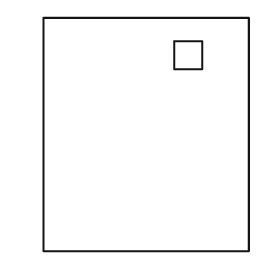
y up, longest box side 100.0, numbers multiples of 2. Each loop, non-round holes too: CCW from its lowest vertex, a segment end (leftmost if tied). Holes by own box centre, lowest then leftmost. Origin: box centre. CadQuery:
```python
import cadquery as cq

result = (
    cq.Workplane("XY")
    .moveTo(-44.0, -50.0)
    .lineTo(44.0, -50.0)
    .lineTo(44.0, 50.0)
    .lineTo(-44.0, 50.0)
    .close()
    .moveTo(12.0, 28.0)
    .lineTo(24.0, 28.0)
    .lineTo(24.0, 40.0)
    .lineTo(12.0, 40.0)
    .close()
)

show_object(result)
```